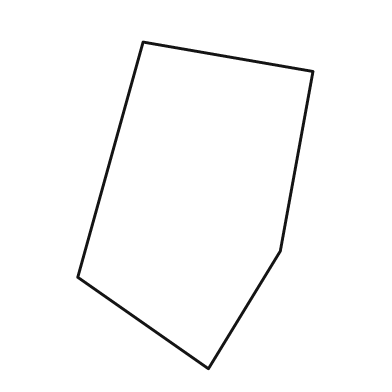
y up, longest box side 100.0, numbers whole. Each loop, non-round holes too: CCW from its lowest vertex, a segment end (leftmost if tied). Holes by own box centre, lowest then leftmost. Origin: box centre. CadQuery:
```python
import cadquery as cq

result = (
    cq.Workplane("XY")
    .moveTo(4.0, -50.0)
    .lineTo(26.0, -14.0)
    .lineTo(36.0, 41.0)
    .lineTo(-16.0, 50.0)
    .lineTo(-36.0, -22.0)
    .close()
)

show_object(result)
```